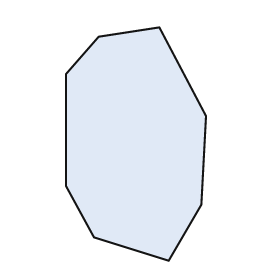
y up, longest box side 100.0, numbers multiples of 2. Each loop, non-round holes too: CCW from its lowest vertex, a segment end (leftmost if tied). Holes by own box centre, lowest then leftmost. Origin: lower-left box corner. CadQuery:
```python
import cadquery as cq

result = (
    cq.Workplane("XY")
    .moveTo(44.0, 0.0)
    .lineTo(58.0, 24.0)
    .lineTo(60.0, 62.0)
    .lineTo(40.0, 100.0)
    .lineTo(14.0, 96.0)
    .lineTo(0.0, 80.0)
    .lineTo(0.0, 32.0)
    .lineTo(12.0, 10.0)
    .close()
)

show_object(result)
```